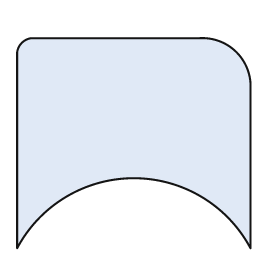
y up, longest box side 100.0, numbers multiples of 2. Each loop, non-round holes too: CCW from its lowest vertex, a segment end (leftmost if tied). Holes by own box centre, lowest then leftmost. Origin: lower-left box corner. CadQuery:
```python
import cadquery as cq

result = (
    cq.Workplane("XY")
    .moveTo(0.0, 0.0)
    .threePointArc((50.0, 30.0), (100.0, 0.0))
    .lineTo(100.0, 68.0)
    .threePointArc((94.0, 84.0), (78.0, 90.0))
    .lineTo(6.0, 90.0)
    .threePointArc((2.0, 88.0), (0.0, 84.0))
    .close()
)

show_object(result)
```